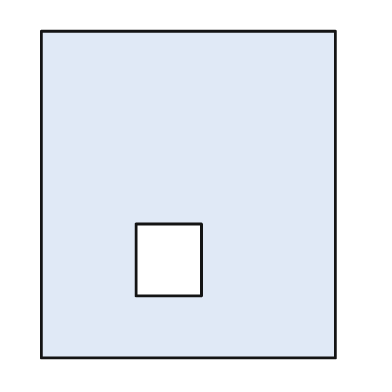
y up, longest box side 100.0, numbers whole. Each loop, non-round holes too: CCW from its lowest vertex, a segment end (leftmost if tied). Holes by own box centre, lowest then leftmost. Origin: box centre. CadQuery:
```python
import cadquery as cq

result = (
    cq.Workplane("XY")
    .moveTo(-45.0, -50.0)
    .lineTo(45.0, -50.0)
    .lineTo(45.0, 50.0)
    .lineTo(-45.0, 50.0)
    .close()
    .moveTo(-16.0, -31.0)
    .lineTo(4.0, -31.0)
    .lineTo(4.0, -9.0)
    .lineTo(-16.0, -9.0)
    .close()
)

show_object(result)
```